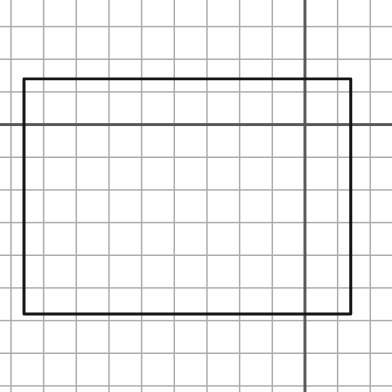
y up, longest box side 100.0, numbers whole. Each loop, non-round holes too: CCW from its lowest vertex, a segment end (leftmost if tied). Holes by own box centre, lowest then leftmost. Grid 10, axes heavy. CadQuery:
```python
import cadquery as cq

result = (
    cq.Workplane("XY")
    .moveTo(-86.0, -58.0)
    .lineTo(14.0, -58.0)
    .lineTo(14.0, 14.0)
    .lineTo(-86.0, 14.0)
    .close()
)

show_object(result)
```